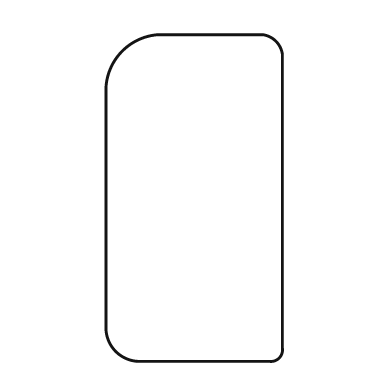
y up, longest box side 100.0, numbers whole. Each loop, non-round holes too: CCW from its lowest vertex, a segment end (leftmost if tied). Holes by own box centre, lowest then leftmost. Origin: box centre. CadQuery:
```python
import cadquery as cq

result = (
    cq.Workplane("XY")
    .moveTo(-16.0, -50.0)
    .lineTo(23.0, -50.0)
    .threePointArc((26.0, -49.0), (27.0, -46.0))
    .lineTo(27.0, 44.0)
    .threePointArc((25.0, 48.0), (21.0, 50.0))
    .lineTo(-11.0, 50.0)
    .threePointArc((-22.0, 45.0), (-27.0, 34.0))
    .lineTo(-27.0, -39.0)
    .threePointArc((-24.0, -47.0), (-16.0, -50.0))
    .close()
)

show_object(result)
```